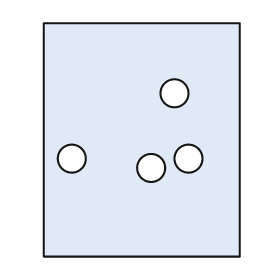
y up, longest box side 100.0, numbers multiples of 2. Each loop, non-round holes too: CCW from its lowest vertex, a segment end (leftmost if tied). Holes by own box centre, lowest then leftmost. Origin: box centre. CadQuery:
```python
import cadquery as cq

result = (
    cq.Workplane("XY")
    .moveTo(-42.0, -50.0)
    .lineTo(42.0, -50.0)
    .lineTo(42.0, 50.0)
    .lineTo(-42.0, 50.0)
    .close()
    .moveTo(4.0, -12.0)
    .circle(6.0)
    .moveTo(-30.0, -8.0)
    .circle(6.0)
    .moveTo(20.0, -8.0)
    .circle(6.0)
    .moveTo(14.0, 20.0)
    .circle(6.0)
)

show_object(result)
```